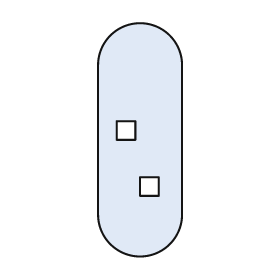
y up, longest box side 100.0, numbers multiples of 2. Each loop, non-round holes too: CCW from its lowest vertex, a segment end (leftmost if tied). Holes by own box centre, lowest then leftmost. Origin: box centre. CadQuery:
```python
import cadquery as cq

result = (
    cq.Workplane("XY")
    .moveTo(-18.0, -32.0)
    .threePointArc((0.0, -50.0), (18.0, -32.0))
    .lineTo(18.0, 32.0)
    .threePointArc((0.0, 50.0), (-18.0, 32.0))
    .close()
    .moveTo(0.0, -24.0)
    .lineTo(8.0, -24.0)
    .lineTo(8.0, -16.0)
    .lineTo(0.0, -16.0)
    .close()
    .moveTo(-10.0, 0.0)
    .lineTo(-2.0, 0.0)
    .lineTo(-2.0, 8.0)
    .lineTo(-10.0, 8.0)
    .close()
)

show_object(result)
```